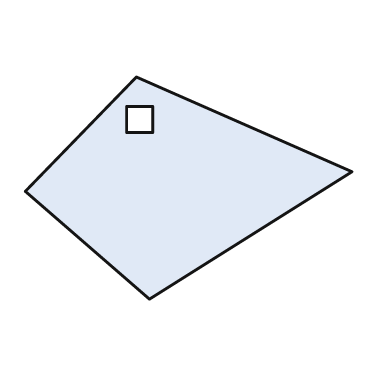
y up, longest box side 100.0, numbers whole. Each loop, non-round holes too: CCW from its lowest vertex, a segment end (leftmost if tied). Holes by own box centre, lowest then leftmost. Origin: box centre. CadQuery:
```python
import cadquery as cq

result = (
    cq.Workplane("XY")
    .moveTo(-12.0, -34.0)
    .lineTo(50.0, 5.0)
    .lineTo(-16.0, 34.0)
    .lineTo(-50.0, -1.0)
    .close()
    .moveTo(-19.0, 17.0)
    .lineTo(-11.0, 17.0)
    .lineTo(-11.0, 25.0)
    .lineTo(-19.0, 25.0)
    .close()
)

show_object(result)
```